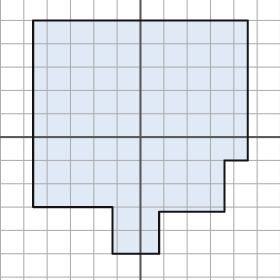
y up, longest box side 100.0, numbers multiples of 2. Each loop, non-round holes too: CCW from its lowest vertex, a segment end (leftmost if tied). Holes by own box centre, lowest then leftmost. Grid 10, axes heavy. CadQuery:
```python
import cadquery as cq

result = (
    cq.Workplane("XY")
    .moveTo(-12.0, -50.0)
    .lineTo(8.0, -50.0)
    .lineTo(8.0, -32.0)
    .lineTo(36.0, -32.0)
    .lineTo(36.0, -10.0)
    .lineTo(46.0, -10.0)
    .lineTo(46.0, 50.0)
    .lineTo(-46.0, 50.0)
    .lineTo(-46.0, -30.0)
    .lineTo(-12.0, -30.0)
    .close()
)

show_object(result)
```